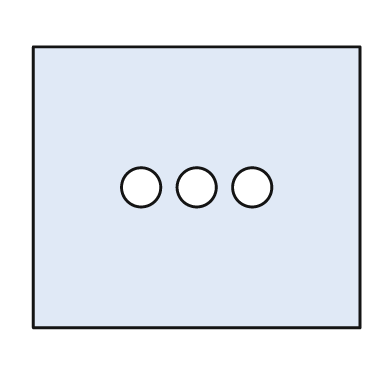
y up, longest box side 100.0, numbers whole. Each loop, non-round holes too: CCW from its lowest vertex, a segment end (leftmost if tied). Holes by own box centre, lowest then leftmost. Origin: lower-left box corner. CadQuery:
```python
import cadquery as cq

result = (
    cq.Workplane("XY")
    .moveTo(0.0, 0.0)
    .lineTo(100.0, 0.0)
    .lineTo(100.0, 86.0)
    .lineTo(0.0, 86.0)
    .close()
    .moveTo(33.0, 43.0)
    .circle(6.0)
    .moveTo(50.0, 43.0)
    .circle(6.0)
    .moveTo(67.0, 43.0)
    .circle(6.0)
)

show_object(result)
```